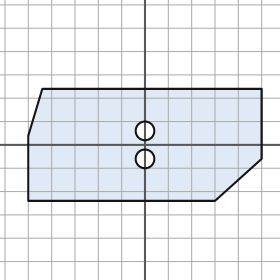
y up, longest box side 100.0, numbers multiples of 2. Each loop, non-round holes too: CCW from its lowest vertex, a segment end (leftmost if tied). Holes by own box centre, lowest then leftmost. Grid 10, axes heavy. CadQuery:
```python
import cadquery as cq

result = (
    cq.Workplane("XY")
    .moveTo(-50.0, -24.0)
    .lineTo(30.0, -24.0)
    .lineTo(50.0, -6.0)
    .lineTo(50.0, 24.0)
    .lineTo(-44.0, 24.0)
    .lineTo(-50.0, 4.0)
    .close()
    .moveTo(0.0, -6.0)
    .circle(4.0)
    .moveTo(0.0, 6.0)
    .circle(4.0)
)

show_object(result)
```